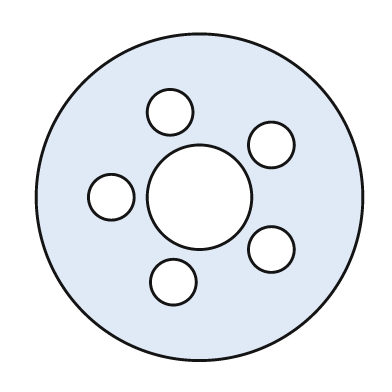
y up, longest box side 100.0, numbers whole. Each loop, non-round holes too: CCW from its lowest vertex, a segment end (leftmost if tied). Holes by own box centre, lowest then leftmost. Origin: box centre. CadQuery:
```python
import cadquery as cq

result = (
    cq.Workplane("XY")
    .moveTo(0.0, 0.0)
    .circle(50.0)
    .moveTo(-8.0, -26.0)
    .circle(7.0)
    .moveTo(22.0, -16.0)
    .circle(7.0)
    .moveTo(-27.0, 0.0)
    .circle(7.0)
    .moveTo(0.0, 0.0)
    .circle(16.0)
    .moveTo(22.0, 16.0)
    .circle(7.0)
    .moveTo(-9.0, 26.0)
    .circle(7.0)
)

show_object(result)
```